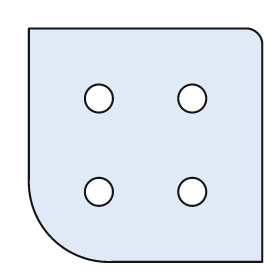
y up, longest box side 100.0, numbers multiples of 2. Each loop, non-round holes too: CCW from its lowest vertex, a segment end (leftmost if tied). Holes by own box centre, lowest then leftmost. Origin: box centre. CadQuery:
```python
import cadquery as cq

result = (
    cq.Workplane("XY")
    .moveTo(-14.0, -50.0)
    .lineTo(50.0, -50.0)
    .lineTo(50.0, 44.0)
    .threePointArc((48.0, 48.0), (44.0, 50.0))
    .lineTo(-50.0, 50.0)
    .lineTo(-50.0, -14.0)
    .threePointArc((-40.0, -40.0), (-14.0, -50.0))
    .close()
    .moveTo(-20.0, -20.0)
    .circle(6.0)
    .moveTo(20.0, -20.0)
    .circle(6.0)
    .moveTo(-20.0, 20.0)
    .circle(6.0)
    .moveTo(20.0, 20.0)
    .circle(6.0)
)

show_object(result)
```